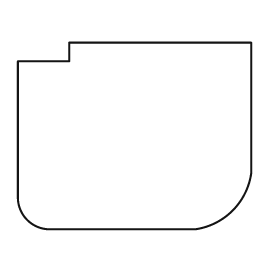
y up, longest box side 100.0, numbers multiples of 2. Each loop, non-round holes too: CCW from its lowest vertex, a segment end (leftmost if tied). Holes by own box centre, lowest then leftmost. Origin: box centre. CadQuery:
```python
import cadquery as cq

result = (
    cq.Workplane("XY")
    .moveTo(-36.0, -40.0)
    .lineTo(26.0, -40.0)
    .threePointArc((42.0, -32.0), (50.0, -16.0))
    .lineTo(50.0, 40.0)
    .lineTo(-28.0, 40.0)
    .lineTo(-28.0, 32.0)
    .lineTo(-50.0, 32.0)
    .lineTo(-50.0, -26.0)
    .threePointArc((-46.0, -36.0), (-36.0, -40.0))
    .close()
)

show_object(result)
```